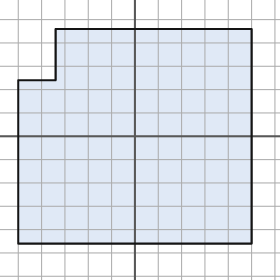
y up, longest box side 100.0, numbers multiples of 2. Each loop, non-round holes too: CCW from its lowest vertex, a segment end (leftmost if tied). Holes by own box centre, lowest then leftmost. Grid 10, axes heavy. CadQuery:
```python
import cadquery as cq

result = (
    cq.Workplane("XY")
    .moveTo(-50.0, -46.0)
    .lineTo(50.0, -46.0)
    .lineTo(50.0, 46.0)
    .lineTo(-34.0, 46.0)
    .lineTo(-34.0, 24.0)
    .lineTo(-50.0, 24.0)
    .close()
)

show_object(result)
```